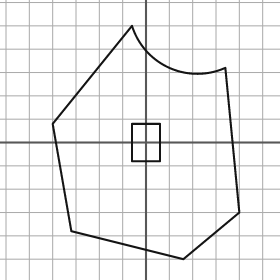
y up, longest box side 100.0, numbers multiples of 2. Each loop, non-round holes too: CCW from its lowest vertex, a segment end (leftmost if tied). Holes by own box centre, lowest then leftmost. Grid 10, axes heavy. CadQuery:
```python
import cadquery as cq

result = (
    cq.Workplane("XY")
    .moveTo(16.0, -50.0)
    .lineTo(40.0, -30.0)
    .lineTo(34.0, 32.0)
    .threePointArc((10.0, 32.0), (-6.0, 50.0))
    .lineTo(-40.0, 8.0)
    .lineTo(-32.0, -38.0)
    .close()
    .moveTo(-6.0, -8.0)
    .lineTo(6.0, -8.0)
    .lineTo(6.0, 8.0)
    .lineTo(-6.0, 8.0)
    .close()
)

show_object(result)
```